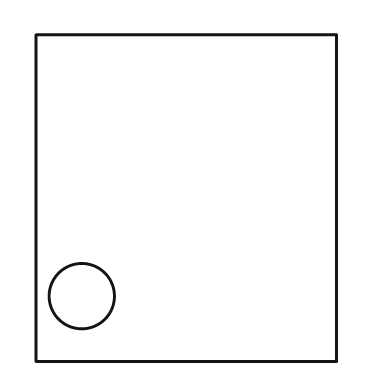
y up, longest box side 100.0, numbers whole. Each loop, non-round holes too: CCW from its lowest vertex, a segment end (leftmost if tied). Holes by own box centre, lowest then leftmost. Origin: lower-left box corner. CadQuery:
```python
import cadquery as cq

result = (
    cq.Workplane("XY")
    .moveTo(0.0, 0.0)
    .lineTo(92.0, 0.0)
    .lineTo(92.0, 100.0)
    .lineTo(0.0, 100.0)
    .close()
    .moveTo(14.0, 20.0)
    .circle(10.0)
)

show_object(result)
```